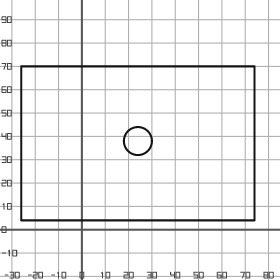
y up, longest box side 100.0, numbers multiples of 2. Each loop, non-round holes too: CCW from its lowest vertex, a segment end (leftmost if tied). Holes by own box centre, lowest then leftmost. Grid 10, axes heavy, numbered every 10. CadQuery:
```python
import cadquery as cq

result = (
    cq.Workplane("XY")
    .moveTo(-26.0, 4.0)
    .lineTo(74.0, 4.0)
    .lineTo(74.0, 70.0)
    .lineTo(-26.0, 70.0)
    .close()
    .moveTo(24.0, 38.0)
    .circle(6.0)
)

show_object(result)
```